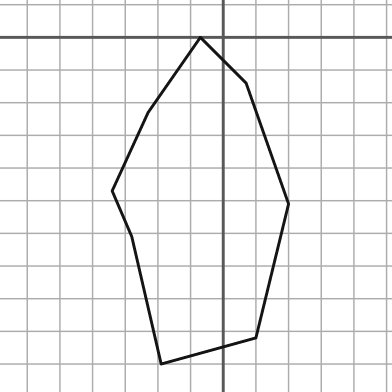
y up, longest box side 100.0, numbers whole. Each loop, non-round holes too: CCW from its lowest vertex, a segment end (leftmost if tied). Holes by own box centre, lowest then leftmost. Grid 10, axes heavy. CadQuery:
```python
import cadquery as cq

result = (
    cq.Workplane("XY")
    .moveTo(-19.0, -100.0)
    .lineTo(10.0, -92.0)
    .lineTo(20.0, -51.0)
    .lineTo(7.0, -14.0)
    .lineTo(-7.0, 0.0)
    .lineTo(-23.0, -23.0)
    .lineTo(-34.0, -47.0)
    .lineTo(-28.0, -61.0)
    .close()
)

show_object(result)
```